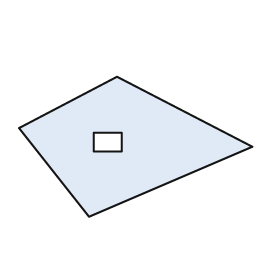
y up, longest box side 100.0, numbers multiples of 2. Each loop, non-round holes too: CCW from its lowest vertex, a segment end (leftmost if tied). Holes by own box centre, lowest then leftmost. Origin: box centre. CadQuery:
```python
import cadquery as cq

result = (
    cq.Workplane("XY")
    .moveTo(-20.0, -30.0)
    .lineTo(50.0, 0.0)
    .lineTo(-8.0, 30.0)
    .lineTo(-50.0, 8.0)
    .close()
    .moveTo(-18.0, -2.0)
    .lineTo(-6.0, -2.0)
    .lineTo(-6.0, 6.0)
    .lineTo(-18.0, 6.0)
    .close()
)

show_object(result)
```